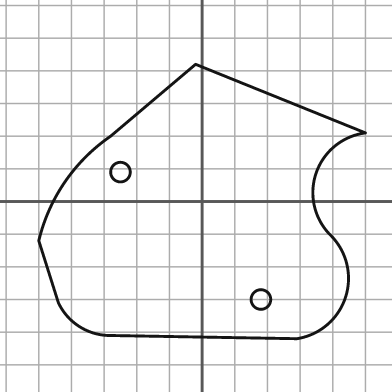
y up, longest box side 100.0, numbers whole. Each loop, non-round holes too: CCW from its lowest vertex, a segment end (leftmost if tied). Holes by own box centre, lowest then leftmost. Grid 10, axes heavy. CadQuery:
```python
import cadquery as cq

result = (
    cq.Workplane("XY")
    .moveTo(29.0, -42.0)
    .threePointArc((44.0, -29.0), (39.0, -10.0))
    .threePointArc((35.0, 9.0), (50.0, 21.0))
    .lineTo(-2.0, 42.0)
    .lineTo(-28.0, 20.0)
    .threePointArc((-42.0, 6.0), (-50.0, -12.0))
    .lineTo(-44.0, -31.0)
    .threePointArc((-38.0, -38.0), (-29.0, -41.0))
    .close()
    .moveTo(18.0, -30.0)
    .circle(3.0)
    .moveTo(-25.0, 9.0)
    .circle(3.0)
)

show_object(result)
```